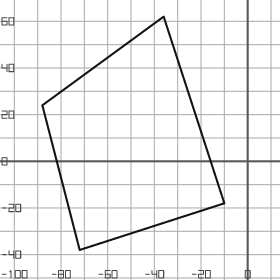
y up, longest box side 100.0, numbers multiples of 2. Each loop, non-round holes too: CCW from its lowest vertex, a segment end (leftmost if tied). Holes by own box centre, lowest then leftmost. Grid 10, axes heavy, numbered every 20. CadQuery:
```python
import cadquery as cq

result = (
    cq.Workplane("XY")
    .moveTo(-72.0, -38.0)
    .lineTo(-10.0, -18.0)
    .lineTo(-36.0, 62.0)
    .lineTo(-88.0, 24.0)
    .close()
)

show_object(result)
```